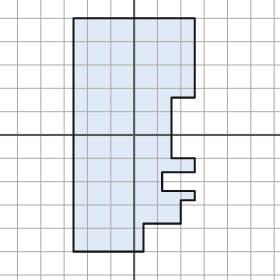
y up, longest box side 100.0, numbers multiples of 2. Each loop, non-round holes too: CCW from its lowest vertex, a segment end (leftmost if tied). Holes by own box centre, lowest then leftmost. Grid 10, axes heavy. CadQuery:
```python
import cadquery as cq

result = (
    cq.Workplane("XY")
    .moveTo(-26.0, -50.0)
    .lineTo(4.0, -50.0)
    .lineTo(4.0, -38.0)
    .lineTo(20.0, -38.0)
    .lineTo(20.0, -28.0)
    .lineTo(26.0, -28.0)
    .lineTo(26.0, -24.0)
    .lineTo(12.0, -24.0)
    .lineTo(12.0, -16.0)
    .lineTo(26.0, -16.0)
    .lineTo(26.0, -10.0)
    .lineTo(16.0, -10.0)
    .lineTo(16.0, 16.0)
    .lineTo(26.0, 16.0)
    .lineTo(26.0, 50.0)
    .lineTo(-26.0, 50.0)
    .close()
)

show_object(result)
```